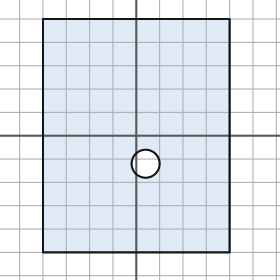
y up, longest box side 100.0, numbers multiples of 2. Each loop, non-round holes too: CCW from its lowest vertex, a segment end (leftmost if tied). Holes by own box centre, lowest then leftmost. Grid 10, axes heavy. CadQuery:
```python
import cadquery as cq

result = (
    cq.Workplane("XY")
    .moveTo(-40.0, -50.0)
    .lineTo(40.0, -50.0)
    .lineTo(40.0, 50.0)
    .lineTo(-40.0, 50.0)
    .close()
    .moveTo(4.0, -12.0)
    .circle(6.0)
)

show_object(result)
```